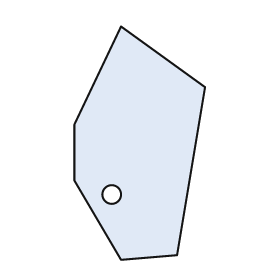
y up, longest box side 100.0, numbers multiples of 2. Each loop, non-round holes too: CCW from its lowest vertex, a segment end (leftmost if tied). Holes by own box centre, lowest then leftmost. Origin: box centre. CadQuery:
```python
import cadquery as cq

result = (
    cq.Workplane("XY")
    .moveTo(-8.0, -50.0)
    .lineTo(16.0, -48.0)
    .lineTo(28.0, 24.0)
    .lineTo(-8.0, 50.0)
    .lineTo(-28.0, 8.0)
    .lineTo(-28.0, -16.0)
    .close()
    .moveTo(-12.0, -22.0)
    .circle(4.0)
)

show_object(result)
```